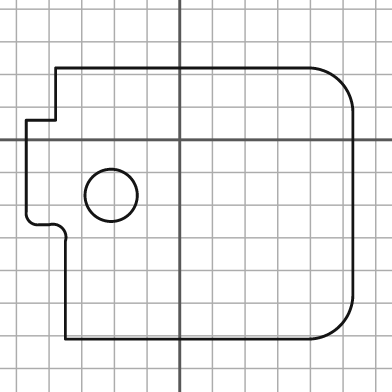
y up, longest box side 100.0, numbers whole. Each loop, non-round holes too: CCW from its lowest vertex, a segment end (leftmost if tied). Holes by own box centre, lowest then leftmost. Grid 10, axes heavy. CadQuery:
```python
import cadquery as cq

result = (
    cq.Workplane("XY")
    .moveTo(-35.0, -61.0)
    .lineTo(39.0, -61.0)
    .threePointArc((49.0, -57.0), (53.0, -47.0))
    .lineTo(53.0, 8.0)
    .threePointArc((49.0, 18.0), (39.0, 22.0))
    .lineTo(-38.0, 22.0)
    .lineTo(-38.0, 6.0)
    .lineTo(-47.0, 6.0)
    .lineTo(-47.0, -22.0)
    .threePointArc((-46.0, -25.0), (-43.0, -26.0))
    .lineTo(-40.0, -26.0)
    .threePointArc((-36.0, -27.0), (-35.0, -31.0))
    .close()
    .moveTo(-21.0, -17.0)
    .circle(8.0)
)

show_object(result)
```